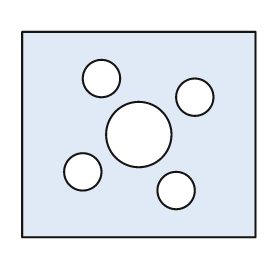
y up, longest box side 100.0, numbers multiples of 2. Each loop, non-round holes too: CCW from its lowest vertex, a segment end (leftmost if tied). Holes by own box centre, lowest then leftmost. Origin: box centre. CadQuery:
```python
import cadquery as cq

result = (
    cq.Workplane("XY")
    .moveTo(-50.0, -44.0)
    .lineTo(50.0, -44.0)
    .lineTo(50.0, 44.0)
    .lineTo(-50.0, 44.0)
    .close()
    .moveTo(16.0, -24.0)
    .circle(8.0)
    .moveTo(-24.0, -16.0)
    .circle(8.0)
    .moveTo(0.0, 0.0)
    .circle(14.0)
    .moveTo(24.0, 16.0)
    .circle(8.0)
    .moveTo(-16.0, 24.0)
    .circle(8.0)
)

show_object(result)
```